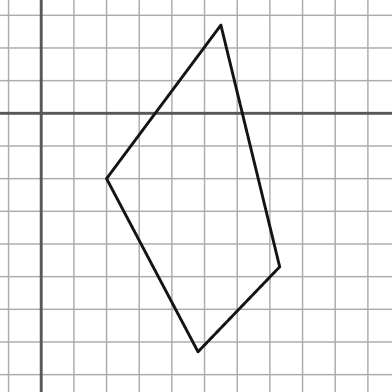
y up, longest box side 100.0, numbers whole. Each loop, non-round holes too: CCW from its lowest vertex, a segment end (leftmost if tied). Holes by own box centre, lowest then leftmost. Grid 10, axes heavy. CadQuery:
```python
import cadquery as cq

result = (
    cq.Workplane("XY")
    .moveTo(48.0, -73.0)
    .lineTo(73.0, -47.0)
    .lineTo(55.0, 27.0)
    .lineTo(20.0, -20.0)
    .close()
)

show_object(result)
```